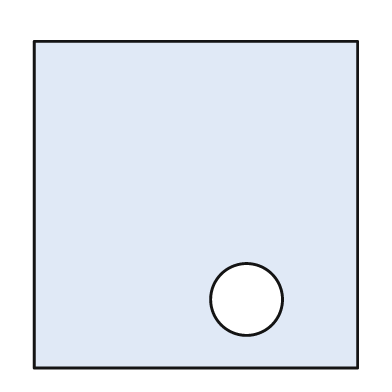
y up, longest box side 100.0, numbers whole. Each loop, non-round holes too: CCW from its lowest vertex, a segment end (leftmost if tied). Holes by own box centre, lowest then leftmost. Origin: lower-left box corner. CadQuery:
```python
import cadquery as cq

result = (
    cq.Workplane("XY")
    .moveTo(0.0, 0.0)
    .lineTo(99.0, 0.0)
    .lineTo(99.0, 100.0)
    .lineTo(0.0, 100.0)
    .close()
    .moveTo(65.0, 21.0)
    .circle(11.0)
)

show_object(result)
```